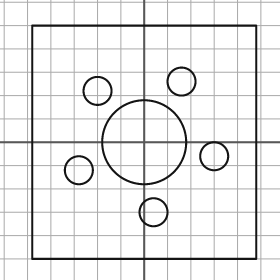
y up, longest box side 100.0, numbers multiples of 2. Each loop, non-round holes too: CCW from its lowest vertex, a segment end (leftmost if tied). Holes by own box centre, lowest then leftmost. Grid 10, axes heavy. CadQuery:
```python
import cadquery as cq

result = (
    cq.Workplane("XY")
    .moveTo(-48.0, -50.0)
    .lineTo(48.0, -50.0)
    .lineTo(48.0, 50.0)
    .lineTo(-48.0, 50.0)
    .close()
    .moveTo(4.0, -30.0)
    .circle(6.0)
    .moveTo(-28.0, -12.0)
    .circle(6.0)
    .moveTo(30.0, -6.0)
    .circle(6.0)
    .moveTo(0.0, 0.0)
    .circle(18.0)
    .moveTo(-20.0, 22.0)
    .circle(6.0)
    .moveTo(16.0, 26.0)
    .circle(6.0)
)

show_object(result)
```